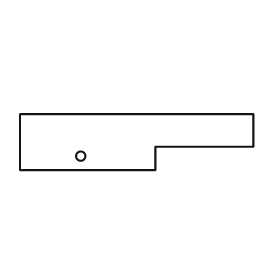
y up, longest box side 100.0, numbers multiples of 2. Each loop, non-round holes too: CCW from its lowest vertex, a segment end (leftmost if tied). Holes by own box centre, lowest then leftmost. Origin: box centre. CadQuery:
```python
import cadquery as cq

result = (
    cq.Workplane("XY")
    .moveTo(-50.0, -12.0)
    .lineTo(8.0, -12.0)
    .lineTo(8.0, -2.0)
    .lineTo(50.0, -2.0)
    .lineTo(50.0, 12.0)
    .lineTo(-50.0, 12.0)
    .close()
    .moveTo(-24.0, -6.0)
    .circle(2.0)
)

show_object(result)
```